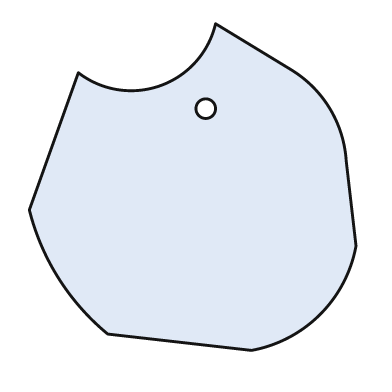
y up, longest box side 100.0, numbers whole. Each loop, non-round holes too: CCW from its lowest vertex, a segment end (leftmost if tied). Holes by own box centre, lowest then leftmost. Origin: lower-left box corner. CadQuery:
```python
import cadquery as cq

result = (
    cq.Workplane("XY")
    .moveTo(68.0, 0.0)
    .threePointArc((89.0, 11.0), (100.0, 32.0))
    .lineTo(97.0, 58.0)
    .threePointArc((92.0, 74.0), (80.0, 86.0))
    .lineTo(57.0, 100.0)
    .threePointArc((40.0, 81.0), (15.0, 85.0))
    .lineTo(0.0, 43.0)
    .threePointArc((9.0, 22.0), (24.0, 5.0))
    .close()
    .moveTo(54.0, 74.0)
    .circle(3.0)
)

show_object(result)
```